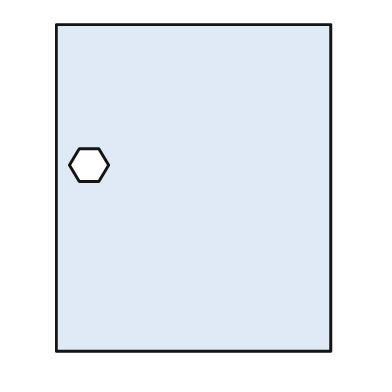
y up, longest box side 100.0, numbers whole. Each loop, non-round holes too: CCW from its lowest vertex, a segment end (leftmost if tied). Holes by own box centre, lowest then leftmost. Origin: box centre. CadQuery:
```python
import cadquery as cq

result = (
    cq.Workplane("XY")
    .moveTo(-42.0, -50.0)
    .lineTo(42.0, -50.0)
    .lineTo(42.0, 50.0)
    .lineTo(-42.0, 50.0)
    .close()
    .moveTo(-35.0, 2.0)
    .lineTo(-29.0, 2.0)
    .lineTo(-26.0, 7.0)
    .lineTo(-29.0, 12.0)
    .lineTo(-35.0, 12.0)
    .lineTo(-38.0, 7.0)
    .close()
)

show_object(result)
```